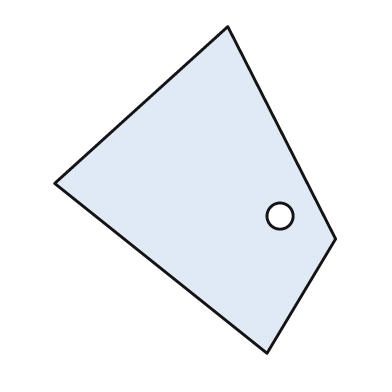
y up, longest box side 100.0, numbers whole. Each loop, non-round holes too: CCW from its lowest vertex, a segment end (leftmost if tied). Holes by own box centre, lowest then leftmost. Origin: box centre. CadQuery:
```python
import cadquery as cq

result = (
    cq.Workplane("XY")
    .moveTo(22.0, -50.0)
    .lineTo(43.0, -15.0)
    .lineTo(10.0, 50.0)
    .lineTo(-43.0, 2.0)
    .close()
    .moveTo(26.0, -8.0)
    .circle(4.0)
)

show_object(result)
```